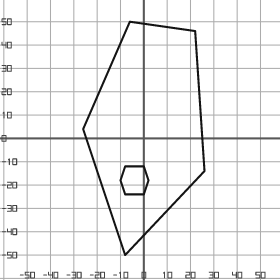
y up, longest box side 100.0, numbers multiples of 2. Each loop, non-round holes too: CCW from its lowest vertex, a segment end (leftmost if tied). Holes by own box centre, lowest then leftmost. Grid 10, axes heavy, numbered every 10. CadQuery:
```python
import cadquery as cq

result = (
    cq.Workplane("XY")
    .moveTo(-8.0, -50.0)
    .lineTo(26.0, -14.0)
    .lineTo(22.0, 46.0)
    .lineTo(-6.0, 50.0)
    .lineTo(-26.0, 4.0)
    .close()
    .moveTo(-8.0, -24.0)
    .lineTo(0.0, -24.0)
    .lineTo(2.0, -18.0)
    .lineTo(0.0, -12.0)
    .lineTo(-8.0, -12.0)
    .lineTo(-10.0, -18.0)
    .close()
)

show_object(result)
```